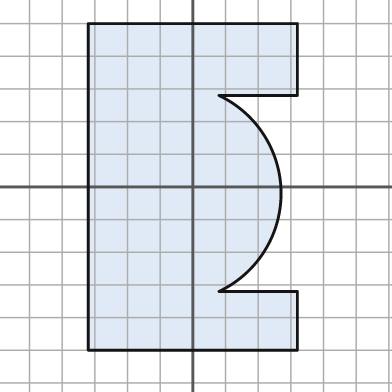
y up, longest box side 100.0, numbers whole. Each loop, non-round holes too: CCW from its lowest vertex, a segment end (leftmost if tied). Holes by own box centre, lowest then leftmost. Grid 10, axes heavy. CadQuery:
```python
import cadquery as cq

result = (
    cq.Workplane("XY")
    .moveTo(-32.0, -50.0)
    .lineTo(32.0, -50.0)
    .lineTo(32.0, -32.0)
    .lineTo(8.0, -32.0)
    .threePointArc((27.0, -2.0), (8.0, 28.0))
    .lineTo(32.0, 28.0)
    .lineTo(32.0, 50.0)
    .lineTo(-32.0, 50.0)
    .close()
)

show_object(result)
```